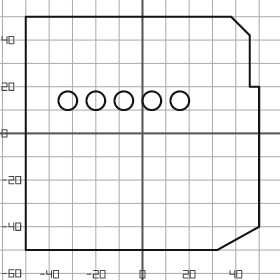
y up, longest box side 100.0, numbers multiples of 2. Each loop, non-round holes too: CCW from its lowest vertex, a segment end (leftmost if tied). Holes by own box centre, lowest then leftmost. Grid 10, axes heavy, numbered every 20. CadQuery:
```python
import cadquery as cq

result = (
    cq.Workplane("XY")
    .moveTo(-50.0, -50.0)
    .lineTo(32.0, -50.0)
    .lineTo(50.0, -40.0)
    .lineTo(50.0, 20.0)
    .lineTo(46.0, 20.0)
    .lineTo(46.0, 42.0)
    .lineTo(38.0, 50.0)
    .lineTo(-50.0, 50.0)
    .close()
    .moveTo(-32.0, 14.0)
    .circle(4.0)
    .moveTo(-20.0, 14.0)
    .circle(4.0)
    .moveTo(-8.0, 14.0)
    .circle(4.0)
    .moveTo(4.0, 14.0)
    .circle(4.0)
    .moveTo(16.0, 14.0)
    .circle(4.0)
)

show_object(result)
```